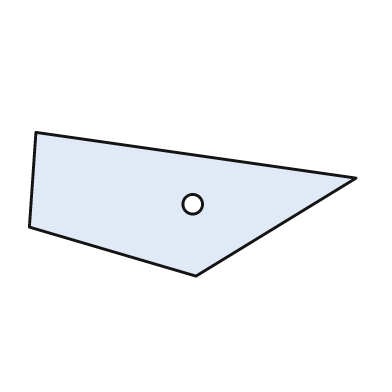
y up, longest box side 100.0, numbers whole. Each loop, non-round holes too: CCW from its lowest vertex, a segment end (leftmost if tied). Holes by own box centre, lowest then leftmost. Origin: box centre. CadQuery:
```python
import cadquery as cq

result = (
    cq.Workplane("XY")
    .moveTo(1.0, -22.0)
    .lineTo(50.0, 8.0)
    .lineTo(-48.0, 22.0)
    .lineTo(-50.0, -7.0)
    .close()
    .moveTo(0.0, 0.0)
    .circle(3.0)
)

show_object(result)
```